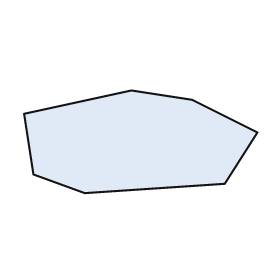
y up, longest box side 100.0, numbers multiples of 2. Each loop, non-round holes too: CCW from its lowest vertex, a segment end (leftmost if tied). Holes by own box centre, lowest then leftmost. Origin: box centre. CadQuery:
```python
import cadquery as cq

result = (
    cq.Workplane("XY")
    .moveTo(-24.0, -22.0)
    .lineTo(36.0, -18.0)
    .lineTo(50.0, 4.0)
    .lineTo(22.0, 18.0)
    .lineTo(-4.0, 22.0)
    .lineTo(-50.0, 12.0)
    .lineTo(-46.0, -14.0)
    .close()
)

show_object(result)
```